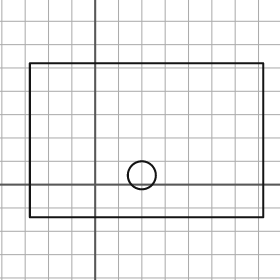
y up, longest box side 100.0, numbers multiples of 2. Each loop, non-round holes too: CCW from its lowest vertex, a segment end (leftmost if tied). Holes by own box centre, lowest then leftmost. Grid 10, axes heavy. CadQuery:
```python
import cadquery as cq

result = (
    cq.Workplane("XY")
    .moveTo(-28.0, -14.0)
    .lineTo(72.0, -14.0)
    .lineTo(72.0, 52.0)
    .lineTo(-28.0, 52.0)
    .close()
    .moveTo(20.0, 4.0)
    .circle(6.0)
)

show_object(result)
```